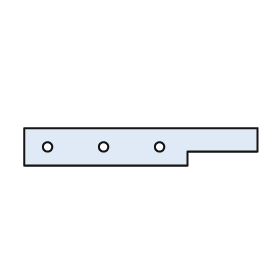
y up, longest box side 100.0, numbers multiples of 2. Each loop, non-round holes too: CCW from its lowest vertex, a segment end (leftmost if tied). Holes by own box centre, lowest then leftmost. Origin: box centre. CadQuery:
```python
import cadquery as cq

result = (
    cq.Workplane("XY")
    .moveTo(-50.0, -8.0)
    .lineTo(20.0, -8.0)
    .lineTo(20.0, -2.0)
    .lineTo(50.0, -2.0)
    .lineTo(50.0, 8.0)
    .lineTo(-50.0, 8.0)
    .close()
    .moveTo(-40.0, 0.0)
    .circle(2.0)
    .moveTo(-16.0, 0.0)
    .circle(2.0)
    .moveTo(8.0, 0.0)
    .circle(2.0)
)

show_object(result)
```